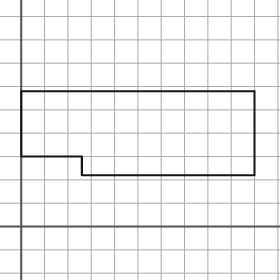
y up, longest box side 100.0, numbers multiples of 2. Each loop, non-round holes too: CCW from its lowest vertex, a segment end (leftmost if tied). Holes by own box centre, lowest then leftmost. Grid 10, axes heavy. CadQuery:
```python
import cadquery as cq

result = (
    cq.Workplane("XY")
    .moveTo(26.0, 22.0)
    .lineTo(100.0, 22.0)
    .lineTo(100.0, 58.0)
    .lineTo(0.0, 58.0)
    .lineTo(0.0, 30.0)
    .lineTo(26.0, 30.0)
    .close()
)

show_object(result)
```